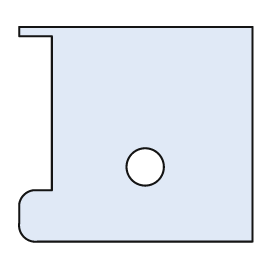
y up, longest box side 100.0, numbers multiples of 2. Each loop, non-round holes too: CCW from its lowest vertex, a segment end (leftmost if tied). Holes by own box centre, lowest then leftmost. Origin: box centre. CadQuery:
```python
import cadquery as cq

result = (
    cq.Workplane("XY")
    .moveTo(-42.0, -46.0)
    .lineTo(50.0, -46.0)
    .lineTo(50.0, 46.0)
    .lineTo(-50.0, 46.0)
    .lineTo(-50.0, 42.0)
    .lineTo(-36.0, 42.0)
    .lineTo(-36.0, -24.0)
    .lineTo(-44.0, -24.0)
    .threePointArc((-48.0, -26.0), (-50.0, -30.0))
    .lineTo(-50.0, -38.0)
    .threePointArc((-48.0, -44.0), (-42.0, -46.0))
    .close()
    .moveTo(4.0, -14.0)
    .circle(8.0)
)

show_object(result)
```